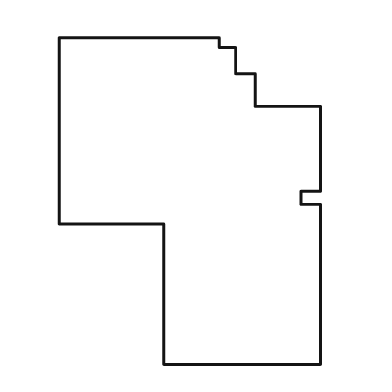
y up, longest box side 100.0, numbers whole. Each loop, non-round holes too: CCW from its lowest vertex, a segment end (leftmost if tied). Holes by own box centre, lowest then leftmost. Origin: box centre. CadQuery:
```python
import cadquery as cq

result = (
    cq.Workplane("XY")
    .moveTo(-8.0, -50.0)
    .lineTo(40.0, -50.0)
    .lineTo(40.0, -1.0)
    .lineTo(34.0, -1.0)
    .lineTo(34.0, 3.0)
    .lineTo(40.0, 3.0)
    .lineTo(40.0, 29.0)
    .lineTo(20.0, 29.0)
    .lineTo(20.0, 39.0)
    .lineTo(14.0, 39.0)
    .lineTo(14.0, 47.0)
    .lineTo(9.0, 47.0)
    .lineTo(9.0, 50.0)
    .lineTo(-40.0, 50.0)
    .lineTo(-40.0, -7.0)
    .lineTo(-8.0, -7.0)
    .close()
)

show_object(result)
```